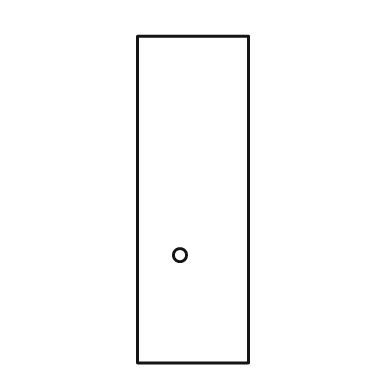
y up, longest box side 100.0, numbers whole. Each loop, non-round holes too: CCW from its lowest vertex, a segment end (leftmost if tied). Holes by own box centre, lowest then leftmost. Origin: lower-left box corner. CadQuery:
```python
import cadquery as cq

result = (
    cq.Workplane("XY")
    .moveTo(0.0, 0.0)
    .lineTo(34.0, 0.0)
    .lineTo(34.0, 100.0)
    .lineTo(0.0, 100.0)
    .close()
    .moveTo(13.0, 33.0)
    .circle(2.0)
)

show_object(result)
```